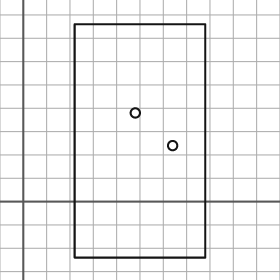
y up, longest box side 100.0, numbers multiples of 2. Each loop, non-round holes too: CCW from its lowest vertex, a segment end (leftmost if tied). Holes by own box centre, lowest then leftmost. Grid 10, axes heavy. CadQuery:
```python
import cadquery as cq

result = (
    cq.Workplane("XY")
    .moveTo(22.0, -24.0)
    .lineTo(78.0, -24.0)
    .lineTo(78.0, 76.0)
    .lineTo(22.0, 76.0)
    .close()
    .moveTo(64.0, 24.0)
    .circle(2.0)
    .moveTo(48.0, 38.0)
    .circle(2.0)
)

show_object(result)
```